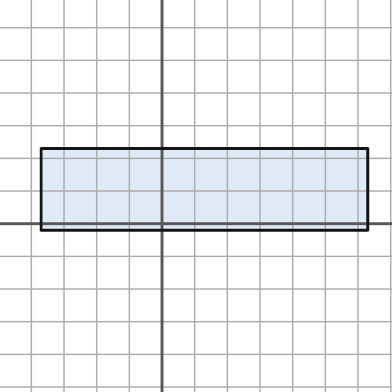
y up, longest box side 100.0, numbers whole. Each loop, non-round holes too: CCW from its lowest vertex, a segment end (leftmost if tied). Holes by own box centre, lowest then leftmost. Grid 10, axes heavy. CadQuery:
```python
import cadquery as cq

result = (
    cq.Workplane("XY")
    .moveTo(-37.0, -2.0)
    .lineTo(63.0, -2.0)
    .lineTo(63.0, 23.0)
    .lineTo(-37.0, 23.0)
    .close()
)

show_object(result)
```